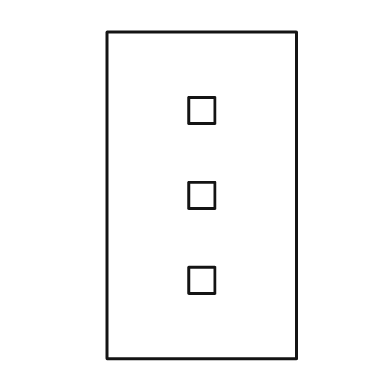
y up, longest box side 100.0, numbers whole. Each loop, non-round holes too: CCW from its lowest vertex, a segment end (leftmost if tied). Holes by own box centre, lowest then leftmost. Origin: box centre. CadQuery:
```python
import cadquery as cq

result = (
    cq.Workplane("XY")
    .moveTo(-29.0, -50.0)
    .lineTo(29.0, -50.0)
    .lineTo(29.0, 50.0)
    .lineTo(-29.0, 50.0)
    .close()
    .moveTo(-4.0, -30.0)
    .lineTo(4.0, -30.0)
    .lineTo(4.0, -22.0)
    .lineTo(-4.0, -22.0)
    .close()
    .moveTo(-4.0, -4.0)
    .lineTo(4.0, -4.0)
    .lineTo(4.0, 4.0)
    .lineTo(-4.0, 4.0)
    .close()
    .moveTo(-4.0, 22.0)
    .lineTo(4.0, 22.0)
    .lineTo(4.0, 30.0)
    .lineTo(-4.0, 30.0)
    .close()
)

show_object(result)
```